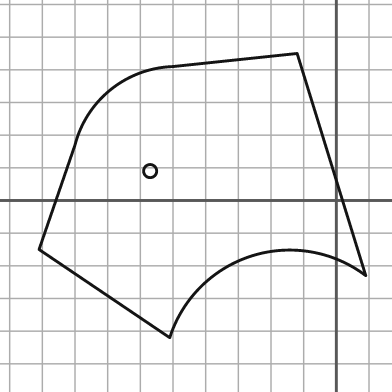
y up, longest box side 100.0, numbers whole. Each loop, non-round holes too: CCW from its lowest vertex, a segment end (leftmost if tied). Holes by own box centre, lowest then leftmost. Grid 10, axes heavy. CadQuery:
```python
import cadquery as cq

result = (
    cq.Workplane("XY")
    .moveTo(-51.0, -42.0)
    .threePointArc((-26.0, -17.0), (9.0, -23.0))
    .lineTo(-12.0, 45.0)
    .lineTo(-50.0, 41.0)
    .threePointArc((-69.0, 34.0), (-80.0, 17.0))
    .lineTo(-91.0, -15.0)
    .close()
    .moveTo(-57.0, 9.0)
    .circle(2.0)
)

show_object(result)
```